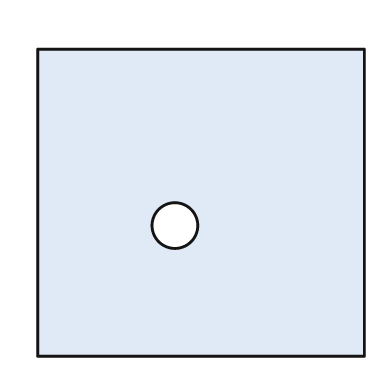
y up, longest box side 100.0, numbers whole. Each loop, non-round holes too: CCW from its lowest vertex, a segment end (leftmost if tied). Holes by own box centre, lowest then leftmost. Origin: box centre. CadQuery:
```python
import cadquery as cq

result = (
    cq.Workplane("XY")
    .moveTo(-50.0, -47.0)
    .lineTo(50.0, -47.0)
    .lineTo(50.0, 47.0)
    .lineTo(-50.0, 47.0)
    .close()
    .moveTo(-8.0, -7.0)
    .circle(7.0)
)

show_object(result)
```